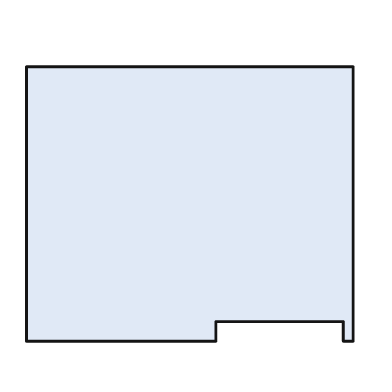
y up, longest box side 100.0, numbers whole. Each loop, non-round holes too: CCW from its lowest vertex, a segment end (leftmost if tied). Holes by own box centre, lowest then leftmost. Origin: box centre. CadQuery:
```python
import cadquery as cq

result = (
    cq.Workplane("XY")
    .moveTo(-50.0, -42.0)
    .lineTo(8.0, -42.0)
    .lineTo(8.0, -36.0)
    .lineTo(47.0, -36.0)
    .lineTo(47.0, -42.0)
    .lineTo(50.0, -42.0)
    .lineTo(50.0, 42.0)
    .lineTo(-50.0, 42.0)
    .close()
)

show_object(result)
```